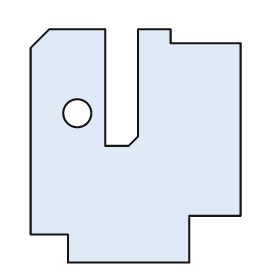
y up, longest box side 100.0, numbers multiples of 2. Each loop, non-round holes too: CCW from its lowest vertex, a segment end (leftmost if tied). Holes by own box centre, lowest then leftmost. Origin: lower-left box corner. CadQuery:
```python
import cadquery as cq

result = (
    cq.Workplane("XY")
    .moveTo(16.0, 0.0)
    .lineTo(68.0, 0.0)
    .lineTo(68.0, 20.0)
    .lineTo(90.0, 20.0)
    .lineTo(90.0, 94.0)
    .lineTo(60.0, 94.0)
    .lineTo(60.0, 100.0)
    .lineTo(46.0, 100.0)
    .lineTo(46.0, 54.0)
    .lineTo(42.0, 50.0)
    .lineTo(32.0, 50.0)
    .lineTo(32.0, 100.0)
    .lineTo(8.0, 100.0)
    .lineTo(0.0, 92.0)
    .lineTo(0.0, 12.0)
    .lineTo(16.0, 12.0)
    .close()
    .moveTo(20.0, 64.0)
    .circle(6.0)
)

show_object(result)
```